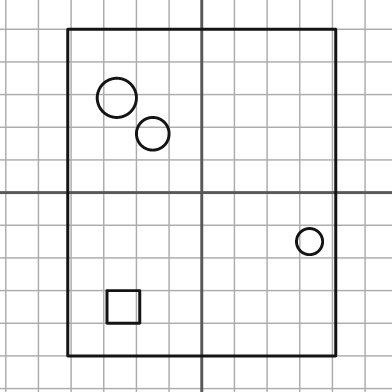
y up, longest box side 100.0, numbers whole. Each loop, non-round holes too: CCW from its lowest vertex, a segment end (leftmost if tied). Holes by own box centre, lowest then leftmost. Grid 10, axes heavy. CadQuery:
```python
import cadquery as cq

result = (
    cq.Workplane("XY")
    .moveTo(-41.0, -50.0)
    .lineTo(41.0, -50.0)
    .lineTo(41.0, 50.0)
    .lineTo(-41.0, 50.0)
    .close()
    .moveTo(-29.0, -40.0)
    .lineTo(-19.0, -40.0)
    .lineTo(-19.0, -30.0)
    .lineTo(-29.0, -30.0)
    .close()
    .moveTo(33.0, -15.0)
    .circle(4.0)
    .moveTo(-15.0, 18.0)
    .circle(5.0)
    .moveTo(-26.0, 29.0)
    .circle(6.0)
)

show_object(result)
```